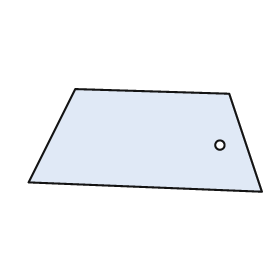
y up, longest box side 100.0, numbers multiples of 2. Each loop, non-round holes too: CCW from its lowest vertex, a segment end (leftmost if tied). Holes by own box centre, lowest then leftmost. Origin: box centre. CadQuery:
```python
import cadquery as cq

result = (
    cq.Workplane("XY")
    .moveTo(50.0, -22.0)
    .lineTo(36.0, 20.0)
    .lineTo(-30.0, 22.0)
    .lineTo(-50.0, -18.0)
    .close()
    .moveTo(32.0, -2.0)
    .circle(2.0)
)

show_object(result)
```